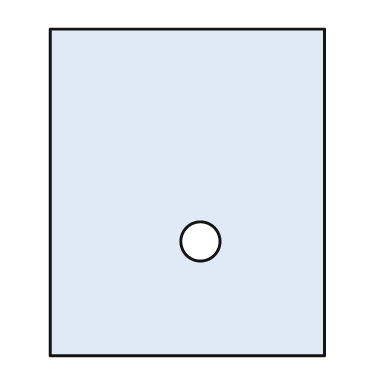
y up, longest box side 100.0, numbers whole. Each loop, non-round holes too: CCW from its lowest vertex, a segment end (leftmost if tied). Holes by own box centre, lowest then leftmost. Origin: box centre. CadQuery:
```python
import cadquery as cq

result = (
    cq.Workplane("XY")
    .moveTo(-42.0, -50.0)
    .lineTo(42.0, -50.0)
    .lineTo(42.0, 50.0)
    .lineTo(-42.0, 50.0)
    .close()
    .moveTo(4.0, -15.0)
    .circle(6.0)
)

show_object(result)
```